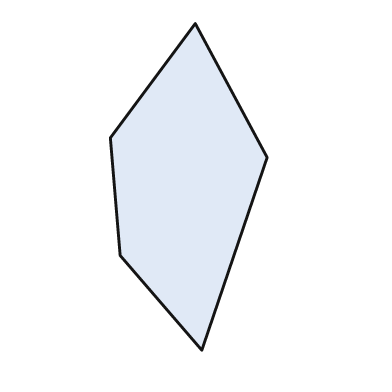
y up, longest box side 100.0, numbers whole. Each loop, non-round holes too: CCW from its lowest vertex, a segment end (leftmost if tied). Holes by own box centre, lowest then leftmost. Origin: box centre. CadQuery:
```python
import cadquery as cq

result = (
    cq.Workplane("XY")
    .moveTo(4.0, -50.0)
    .lineTo(24.0, 9.0)
    .lineTo(2.0, 50.0)
    .lineTo(-24.0, 15.0)
    .lineTo(-21.0, -21.0)
    .close()
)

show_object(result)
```